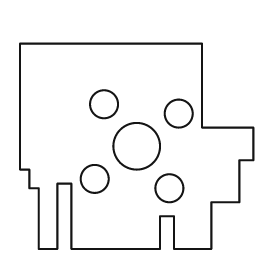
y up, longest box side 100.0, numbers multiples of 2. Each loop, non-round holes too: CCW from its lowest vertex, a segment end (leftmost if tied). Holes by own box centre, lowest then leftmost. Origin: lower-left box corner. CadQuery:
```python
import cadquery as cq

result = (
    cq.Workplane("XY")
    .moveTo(8.0, 0.0)
    .lineTo(16.0, 0.0)
    .lineTo(16.0, 28.0)
    .lineTo(22.0, 28.0)
    .lineTo(22.0, 0.0)
    .lineTo(60.0, 0.0)
    .lineTo(60.0, 14.0)
    .lineTo(66.0, 14.0)
    .lineTo(66.0, 0.0)
    .lineTo(82.0, 0.0)
    .lineTo(82.0, 20.0)
    .lineTo(94.0, 20.0)
    .lineTo(94.0, 38.0)
    .lineTo(100.0, 38.0)
    .lineTo(100.0, 52.0)
    .lineTo(78.0, 52.0)
    .lineTo(78.0, 88.0)
    .lineTo(0.0, 88.0)
    .lineTo(0.0, 34.0)
    .lineTo(4.0, 34.0)
    .lineTo(4.0, 26.0)
    .lineTo(8.0, 26.0)
    .close()
    .moveTo(64.0, 26.0)
    .circle(6.0)
    .moveTo(32.0, 30.0)
    .circle(6.0)
    .moveTo(50.0, 44.0)
    .circle(10.0)
    .moveTo(68.0, 58.0)
    .circle(6.0)
    .moveTo(36.0, 62.0)
    .circle(6.0)
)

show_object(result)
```